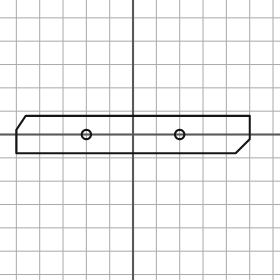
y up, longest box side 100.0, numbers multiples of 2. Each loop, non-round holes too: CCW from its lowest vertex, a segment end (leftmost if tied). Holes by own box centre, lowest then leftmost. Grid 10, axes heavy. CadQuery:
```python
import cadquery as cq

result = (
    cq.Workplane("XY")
    .moveTo(-50.0, -8.0)
    .lineTo(44.0, -8.0)
    .lineTo(50.0, -2.0)
    .lineTo(50.0, 8.0)
    .lineTo(-46.0, 8.0)
    .lineTo(-50.0, 2.0)
    .close()
    .moveTo(-20.0, 0.0)
    .circle(2.0)
    .moveTo(20.0, 0.0)
    .circle(2.0)
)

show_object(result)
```